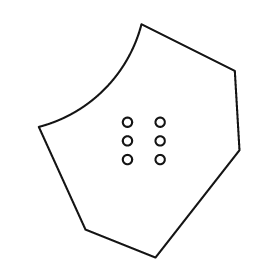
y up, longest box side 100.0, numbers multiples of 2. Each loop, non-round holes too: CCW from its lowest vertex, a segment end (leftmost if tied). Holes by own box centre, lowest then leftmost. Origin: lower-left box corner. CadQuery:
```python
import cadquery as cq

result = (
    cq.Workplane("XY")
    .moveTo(50.0, 0.0)
    .lineTo(86.0, 46.0)
    .lineTo(84.0, 80.0)
    .lineTo(44.0, 100.0)
    .threePointArc((28.0, 72.0), (0.0, 56.0))
    .lineTo(20.0, 12.0)
    .close()
    .moveTo(38.0, 42.0)
    .circle(2.0)
    .moveTo(52.0, 42.0)
    .circle(2.0)
    .moveTo(38.0, 50.0)
    .circle(2.0)
    .moveTo(52.0, 50.0)
    .circle(2.0)
    .moveTo(38.0, 58.0)
    .circle(2.0)
    .moveTo(52.0, 58.0)
    .circle(2.0)
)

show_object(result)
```